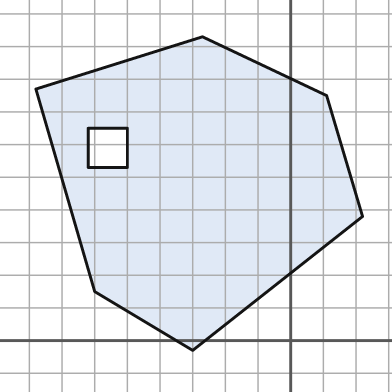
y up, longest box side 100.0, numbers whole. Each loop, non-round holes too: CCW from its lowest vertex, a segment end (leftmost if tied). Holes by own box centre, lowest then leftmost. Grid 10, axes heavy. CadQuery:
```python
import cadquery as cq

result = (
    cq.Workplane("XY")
    .moveTo(-30.0, -3.0)
    .lineTo(22.0, 38.0)
    .lineTo(11.0, 75.0)
    .lineTo(-27.0, 93.0)
    .lineTo(-78.0, 77.0)
    .lineTo(-60.0, 15.0)
    .close()
    .moveTo(-62.0, 53.0)
    .lineTo(-50.0, 53.0)
    .lineTo(-50.0, 65.0)
    .lineTo(-62.0, 65.0)
    .close()
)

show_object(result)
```